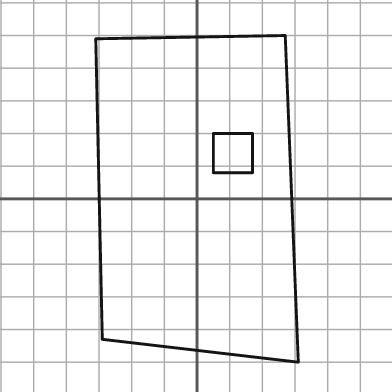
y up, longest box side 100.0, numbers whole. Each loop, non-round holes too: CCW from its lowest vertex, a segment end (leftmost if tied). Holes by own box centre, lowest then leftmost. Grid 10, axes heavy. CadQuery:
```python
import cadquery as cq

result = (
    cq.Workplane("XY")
    .moveTo(31.0, -50.0)
    .lineTo(27.0, 50.0)
    .lineTo(-31.0, 49.0)
    .lineTo(-29.0, -43.0)
    .close()
    .moveTo(5.0, 8.0)
    .lineTo(17.0, 8.0)
    .lineTo(17.0, 20.0)
    .lineTo(5.0, 20.0)
    .close()
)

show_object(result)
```